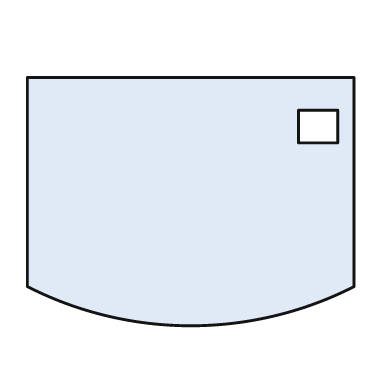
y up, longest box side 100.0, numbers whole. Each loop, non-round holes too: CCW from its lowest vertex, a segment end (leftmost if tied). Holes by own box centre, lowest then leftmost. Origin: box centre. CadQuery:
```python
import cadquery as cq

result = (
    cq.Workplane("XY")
    .moveTo(-50.0, -26.0)
    .threePointArc((0.0, -38.0), (50.0, -26.0))
    .lineTo(50.0, 38.0)
    .lineTo(-50.0, 38.0)
    .close()
    .moveTo(33.0, 18.0)
    .lineTo(45.0, 18.0)
    .lineTo(45.0, 28.0)
    .lineTo(33.0, 28.0)
    .close()
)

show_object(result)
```